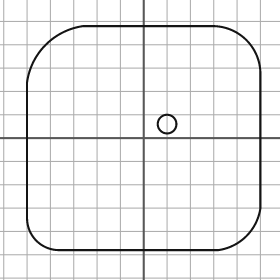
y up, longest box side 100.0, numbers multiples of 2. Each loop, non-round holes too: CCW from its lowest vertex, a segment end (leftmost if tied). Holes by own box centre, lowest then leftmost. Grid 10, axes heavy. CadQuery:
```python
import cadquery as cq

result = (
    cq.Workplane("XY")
    .moveTo(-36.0, -48.0)
    .lineTo(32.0, -48.0)
    .threePointArc((44.0, -42.0), (50.0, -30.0))
    .lineTo(50.0, 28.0)
    .threePointArc((44.0, 42.0), (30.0, 48.0))
    .lineTo(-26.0, 48.0)
    .threePointArc((-42.0, 40.0), (-50.0, 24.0))
    .lineTo(-50.0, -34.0)
    .threePointArc((-46.0, -44.0), (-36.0, -48.0))
    .close()
    .moveTo(10.0, 6.0)
    .circle(4.0)
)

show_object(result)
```